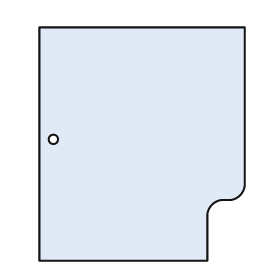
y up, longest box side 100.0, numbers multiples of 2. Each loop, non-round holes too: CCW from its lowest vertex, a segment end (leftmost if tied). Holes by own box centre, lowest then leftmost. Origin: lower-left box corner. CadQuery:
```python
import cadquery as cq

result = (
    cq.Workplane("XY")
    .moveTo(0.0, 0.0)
    .lineTo(72.0, 0.0)
    .lineTo(72.0, 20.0)
    .threePointArc((74.0, 24.0), (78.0, 26.0))
    .lineTo(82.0, 26.0)
    .threePointArc((86.0, 28.0), (88.0, 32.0))
    .lineTo(88.0, 100.0)
    .lineTo(0.0, 100.0)
    .close()
    .moveTo(6.0, 52.0)
    .circle(2.0)
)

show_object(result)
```